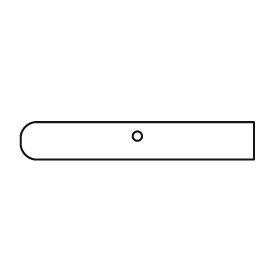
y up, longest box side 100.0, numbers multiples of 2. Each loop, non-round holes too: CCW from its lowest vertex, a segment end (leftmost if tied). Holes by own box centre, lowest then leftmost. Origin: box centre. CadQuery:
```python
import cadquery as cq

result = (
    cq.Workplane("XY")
    .moveTo(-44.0, -8.0)
    .lineTo(50.0, -8.0)
    .lineTo(50.0, 8.0)
    .lineTo(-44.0, 8.0)
    .threePointArc((-48.0, 6.0), (-50.0, 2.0))
    .lineTo(-50.0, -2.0)
    .threePointArc((-48.0, -6.0), (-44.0, -8.0))
    .close()
    .moveTo(0.0, 2.0)
    .circle(2.0)
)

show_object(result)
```